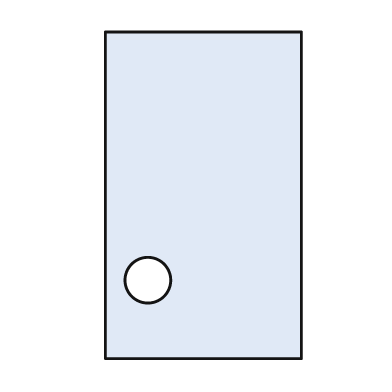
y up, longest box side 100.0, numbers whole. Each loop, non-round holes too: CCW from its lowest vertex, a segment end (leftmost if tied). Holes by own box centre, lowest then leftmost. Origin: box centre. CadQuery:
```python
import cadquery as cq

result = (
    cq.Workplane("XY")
    .moveTo(-30.0, -50.0)
    .lineTo(30.0, -50.0)
    .lineTo(30.0, 50.0)
    .lineTo(-30.0, 50.0)
    .close()
    .moveTo(-17.0, -26.0)
    .circle(7.0)
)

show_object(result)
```